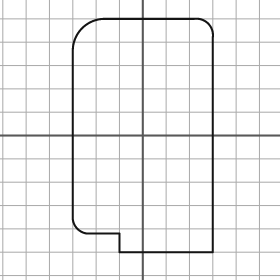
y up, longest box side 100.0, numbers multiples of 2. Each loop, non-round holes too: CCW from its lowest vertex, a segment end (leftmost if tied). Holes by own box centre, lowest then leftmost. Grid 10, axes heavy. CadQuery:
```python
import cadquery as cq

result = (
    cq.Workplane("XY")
    .moveTo(-10.0, -50.0)
    .lineTo(30.0, -50.0)
    .lineTo(30.0, 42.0)
    .threePointArc((28.0, 48.0), (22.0, 50.0))
    .lineTo(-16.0, 50.0)
    .threePointArc((-26.0, 46.0), (-30.0, 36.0))
    .lineTo(-30.0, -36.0)
    .threePointArc((-28.0, -40.0), (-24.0, -42.0))
    .lineTo(-10.0, -42.0)
    .close()
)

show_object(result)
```